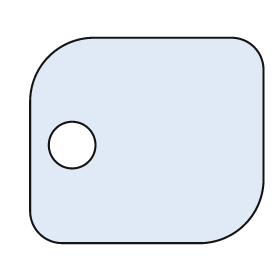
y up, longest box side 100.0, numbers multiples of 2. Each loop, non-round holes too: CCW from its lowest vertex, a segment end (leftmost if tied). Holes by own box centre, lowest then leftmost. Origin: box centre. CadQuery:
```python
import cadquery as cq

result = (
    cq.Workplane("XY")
    .moveTo(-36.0, -44.0)
    .lineTo(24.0, -44.0)
    .threePointArc((42.0, -36.0), (50.0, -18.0))
    .lineTo(50.0, 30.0)
    .threePointArc((46.0, 40.0), (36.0, 44.0))
    .lineTo(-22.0, 44.0)
    .threePointArc((-42.0, 36.0), (-50.0, 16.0))
    .lineTo(-50.0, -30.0)
    .threePointArc((-46.0, -40.0), (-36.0, -44.0))
    .close()
    .moveTo(-32.0, -2.0)
    .circle(10.0)
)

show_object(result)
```